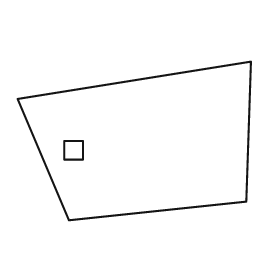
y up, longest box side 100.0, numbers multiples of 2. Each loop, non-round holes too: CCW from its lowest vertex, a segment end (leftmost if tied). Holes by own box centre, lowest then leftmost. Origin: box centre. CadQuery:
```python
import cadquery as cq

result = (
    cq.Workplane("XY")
    .moveTo(-28.0, -34.0)
    .lineTo(48.0, -26.0)
    .lineTo(50.0, 34.0)
    .lineTo(-50.0, 18.0)
    .close()
    .moveTo(-30.0, -8.0)
    .lineTo(-22.0, -8.0)
    .lineTo(-22.0, 0.0)
    .lineTo(-30.0, 0.0)
    .close()
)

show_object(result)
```